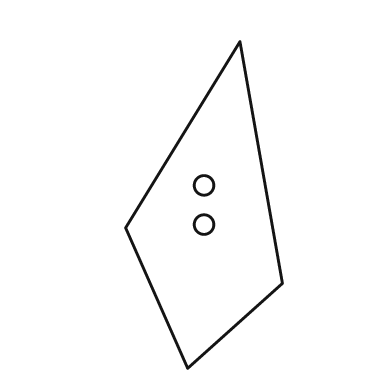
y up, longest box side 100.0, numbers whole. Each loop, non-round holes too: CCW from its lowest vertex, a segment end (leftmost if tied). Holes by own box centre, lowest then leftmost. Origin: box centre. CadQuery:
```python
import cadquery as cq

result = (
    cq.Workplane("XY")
    .moveTo(-5.0, -50.0)
    .lineTo(24.0, -24.0)
    .lineTo(11.0, 50.0)
    .lineTo(-24.0, -7.0)
    .close()
    .moveTo(0.0, -6.0)
    .circle(3.0)
    .moveTo(0.0, 6.0)
    .circle(3.0)
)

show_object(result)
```